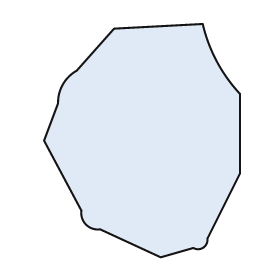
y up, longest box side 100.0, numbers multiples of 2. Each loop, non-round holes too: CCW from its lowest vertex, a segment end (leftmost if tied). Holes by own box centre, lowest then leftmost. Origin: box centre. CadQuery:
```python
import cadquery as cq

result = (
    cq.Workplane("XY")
    .moveTo(8.0, -50.0)
    .lineTo(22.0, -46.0)
    .threePointArc((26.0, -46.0), (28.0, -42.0))
    .lineTo(42.0, -14.0)
    .lineTo(42.0, 20.0)
    .threePointArc((32.0, 34.0), (26.0, 50.0))
    .lineTo(-12.0, 48.0)
    .lineTo(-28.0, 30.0)
    .threePointArc((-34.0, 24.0), (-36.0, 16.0))
    .lineTo(-42.0, 0.0)
    .lineTo(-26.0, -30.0)
    .threePointArc((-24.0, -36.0), (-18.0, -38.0))
    .close()
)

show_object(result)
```